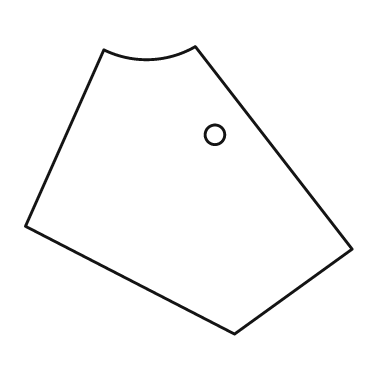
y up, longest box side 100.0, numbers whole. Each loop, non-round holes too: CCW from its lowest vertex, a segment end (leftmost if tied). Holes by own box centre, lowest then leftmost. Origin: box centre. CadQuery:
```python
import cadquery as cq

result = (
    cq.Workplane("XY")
    .moveTo(14.0, -44.0)
    .lineTo(50.0, -18.0)
    .lineTo(2.0, 44.0)
    .threePointArc((-12.0, 40.0), (-26.0, 43.0))
    .lineTo(-50.0, -11.0)
    .close()
    .moveTo(8.0, 17.0)
    .circle(3.0)
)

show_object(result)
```